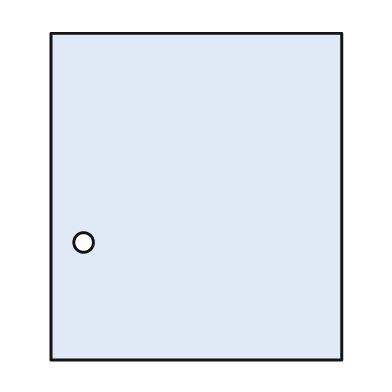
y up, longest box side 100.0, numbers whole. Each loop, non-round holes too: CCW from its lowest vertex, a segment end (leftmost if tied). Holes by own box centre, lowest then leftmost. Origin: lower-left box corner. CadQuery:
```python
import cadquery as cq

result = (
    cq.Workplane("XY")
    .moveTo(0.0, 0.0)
    .lineTo(89.0, 0.0)
    .lineTo(89.0, 100.0)
    .lineTo(0.0, 100.0)
    .close()
    .moveTo(10.0, 36.0)
    .circle(3.0)
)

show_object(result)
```